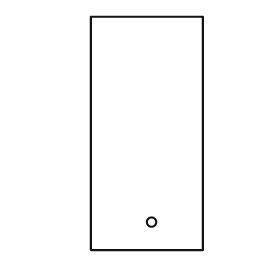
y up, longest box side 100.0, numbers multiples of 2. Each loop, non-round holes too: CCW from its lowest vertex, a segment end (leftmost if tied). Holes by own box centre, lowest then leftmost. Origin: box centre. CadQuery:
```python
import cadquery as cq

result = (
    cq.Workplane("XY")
    .moveTo(-24.0, -50.0)
    .lineTo(24.0, -50.0)
    .lineTo(24.0, 50.0)
    .lineTo(-24.0, 50.0)
    .close()
    .moveTo(2.0, -38.0)
    .circle(2.0)
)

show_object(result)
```